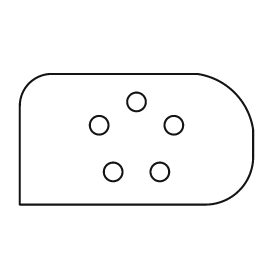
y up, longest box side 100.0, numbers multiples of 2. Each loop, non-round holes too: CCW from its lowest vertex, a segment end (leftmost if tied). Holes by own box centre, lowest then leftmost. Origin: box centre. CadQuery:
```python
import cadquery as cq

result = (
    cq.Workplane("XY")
    .moveTo(-50.0, -28.0)
    .lineTo(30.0, -28.0)
    .threePointArc((44.0, -22.0), (50.0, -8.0))
    .lineTo(50.0, 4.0)
    .threePointArc((42.0, 20.0), (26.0, 28.0))
    .lineTo(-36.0, 28.0)
    .threePointArc((-46.0, 24.0), (-50.0, 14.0))
    .close()
    .moveTo(-10.0, -14.0)
    .circle(4.0)
    .moveTo(10.0, -14.0)
    .circle(4.0)
    .moveTo(-16.0, 6.0)
    .circle(4.0)
    .moveTo(16.0, 6.0)
    .circle(4.0)
    .moveTo(0.0, 16.0)
    .circle(4.0)
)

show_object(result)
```